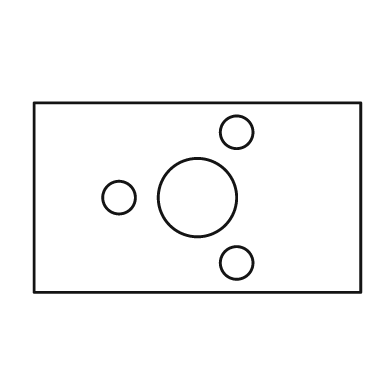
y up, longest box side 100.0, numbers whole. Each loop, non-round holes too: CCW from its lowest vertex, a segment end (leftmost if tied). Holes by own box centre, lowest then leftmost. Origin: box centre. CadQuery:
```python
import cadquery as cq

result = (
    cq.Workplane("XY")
    .moveTo(-50.0, -29.0)
    .lineTo(50.0, -29.0)
    .lineTo(50.0, 29.0)
    .lineTo(-50.0, 29.0)
    .close()
    .moveTo(12.0, -20.0)
    .circle(5.0)
    .moveTo(-24.0, 0.0)
    .circle(5.0)
    .moveTo(0.0, 0.0)
    .circle(12.0)
    .moveTo(12.0, 20.0)
    .circle(5.0)
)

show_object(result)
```